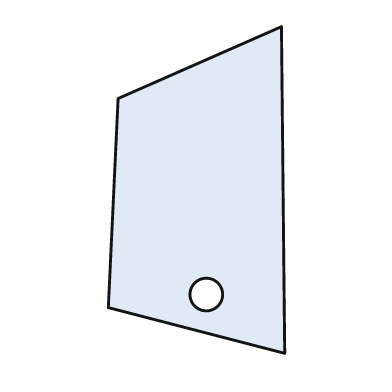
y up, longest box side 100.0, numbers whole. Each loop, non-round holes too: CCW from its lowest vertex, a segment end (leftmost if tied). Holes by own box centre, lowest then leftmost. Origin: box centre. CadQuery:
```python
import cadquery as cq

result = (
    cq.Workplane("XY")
    .moveTo(27.0, -50.0)
    .lineTo(26.0, 50.0)
    .lineTo(-24.0, 28.0)
    .lineTo(-27.0, -36.0)
    .close()
    .moveTo(3.0, -32.0)
    .circle(5.0)
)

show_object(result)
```